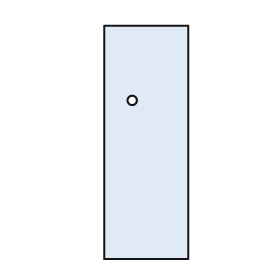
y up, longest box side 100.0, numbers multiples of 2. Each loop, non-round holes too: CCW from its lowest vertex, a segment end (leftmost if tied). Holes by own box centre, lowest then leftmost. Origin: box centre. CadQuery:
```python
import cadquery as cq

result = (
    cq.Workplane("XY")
    .moveTo(-18.0, -50.0)
    .lineTo(18.0, -50.0)
    .lineTo(18.0, 50.0)
    .lineTo(-18.0, 50.0)
    .close()
    .moveTo(-6.0, 18.0)
    .circle(2.0)
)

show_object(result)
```